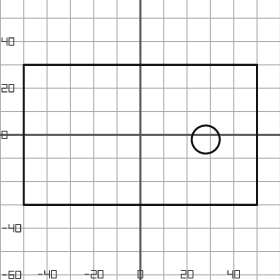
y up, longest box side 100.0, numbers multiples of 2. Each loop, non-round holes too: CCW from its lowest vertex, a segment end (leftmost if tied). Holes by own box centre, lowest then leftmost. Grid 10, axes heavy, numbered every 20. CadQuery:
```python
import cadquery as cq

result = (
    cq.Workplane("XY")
    .moveTo(-50.0, -30.0)
    .lineTo(50.0, -30.0)
    .lineTo(50.0, 30.0)
    .lineTo(-50.0, 30.0)
    .close()
    .moveTo(28.0, -2.0)
    .circle(6.0)
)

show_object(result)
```